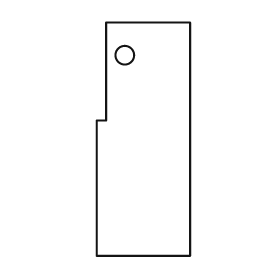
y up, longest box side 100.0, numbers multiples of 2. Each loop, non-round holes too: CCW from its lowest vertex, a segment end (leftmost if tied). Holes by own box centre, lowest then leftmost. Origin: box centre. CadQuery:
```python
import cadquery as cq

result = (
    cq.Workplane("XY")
    .moveTo(-20.0, -50.0)
    .lineTo(20.0, -50.0)
    .lineTo(20.0, 50.0)
    .lineTo(-16.0, 50.0)
    .lineTo(-16.0, 8.0)
    .lineTo(-20.0, 8.0)
    .close()
    .moveTo(-8.0, 36.0)
    .circle(4.0)
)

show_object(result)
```